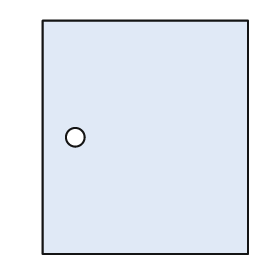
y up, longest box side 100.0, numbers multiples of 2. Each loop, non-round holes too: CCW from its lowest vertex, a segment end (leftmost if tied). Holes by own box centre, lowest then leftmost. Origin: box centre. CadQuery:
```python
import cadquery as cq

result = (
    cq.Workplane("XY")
    .moveTo(-44.0, -50.0)
    .lineTo(44.0, -50.0)
    .lineTo(44.0, 50.0)
    .lineTo(-44.0, 50.0)
    .close()
    .moveTo(-30.0, 0.0)
    .circle(4.0)
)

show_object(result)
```